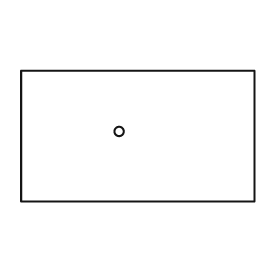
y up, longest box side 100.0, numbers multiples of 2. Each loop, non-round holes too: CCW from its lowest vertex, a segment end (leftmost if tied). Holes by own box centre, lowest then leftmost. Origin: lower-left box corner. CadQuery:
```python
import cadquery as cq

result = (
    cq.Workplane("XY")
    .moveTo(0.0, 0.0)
    .lineTo(100.0, 0.0)
    .lineTo(100.0, 56.0)
    .lineTo(0.0, 56.0)
    .close()
    .moveTo(42.0, 30.0)
    .circle(2.0)
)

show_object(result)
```